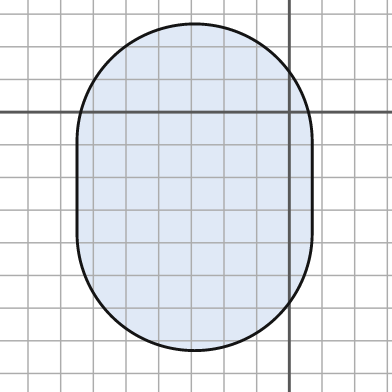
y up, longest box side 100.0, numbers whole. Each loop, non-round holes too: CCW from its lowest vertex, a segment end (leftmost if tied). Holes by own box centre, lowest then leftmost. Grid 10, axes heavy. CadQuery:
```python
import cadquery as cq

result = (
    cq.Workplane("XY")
    .moveTo(-65.0, -37.0)
    .threePointArc((-29.0, -73.0), (7.0, -37.0))
    .lineTo(7.0, -9.0)
    .threePointArc((-29.0, 27.0), (-65.0, -9.0))
    .close()
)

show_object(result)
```